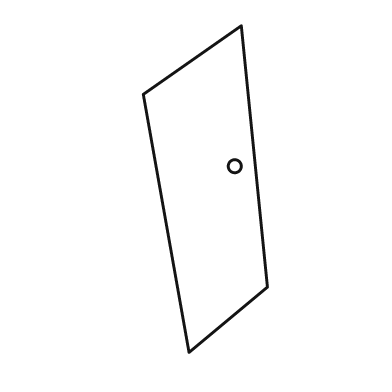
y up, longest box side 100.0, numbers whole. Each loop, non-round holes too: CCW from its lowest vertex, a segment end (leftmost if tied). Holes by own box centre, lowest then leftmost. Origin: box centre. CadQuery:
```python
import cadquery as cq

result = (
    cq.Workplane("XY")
    .moveTo(-5.0, -50.0)
    .lineTo(19.0, -30.0)
    .lineTo(11.0, 50.0)
    .lineTo(-19.0, 29.0)
    .close()
    .moveTo(9.0, 7.0)
    .circle(2.0)
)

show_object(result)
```